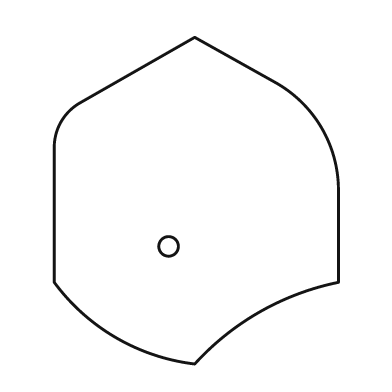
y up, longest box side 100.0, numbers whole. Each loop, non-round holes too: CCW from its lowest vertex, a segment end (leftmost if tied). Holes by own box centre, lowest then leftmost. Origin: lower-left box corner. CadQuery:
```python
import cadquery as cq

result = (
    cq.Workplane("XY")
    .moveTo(43.0, 0.0)
    .threePointArc((63.0, 16.0), (87.0, 25.0))
    .lineTo(87.0, 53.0)
    .threePointArc((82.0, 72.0), (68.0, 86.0))
    .lineTo(43.0, 100.0)
    .lineTo(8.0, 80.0)
    .threePointArc((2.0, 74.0), (0.0, 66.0))
    .lineTo(0.0, 25.0)
    .threePointArc((19.0, 8.0), (43.0, 0.0))
    .close()
    .moveTo(35.0, 36.0)
    .circle(3.0)
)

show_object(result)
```